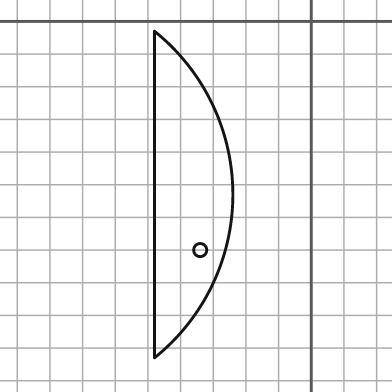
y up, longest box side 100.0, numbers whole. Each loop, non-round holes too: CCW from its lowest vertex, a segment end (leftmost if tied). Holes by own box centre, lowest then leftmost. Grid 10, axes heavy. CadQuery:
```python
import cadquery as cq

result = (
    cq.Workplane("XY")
    .moveTo(-48.0, -103.0)
    .threePointArc((-24.0, -53.0), (-48.0, -3.0))
    .close()
    .moveTo(-34.0, -70.0)
    .circle(2.0)
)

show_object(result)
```